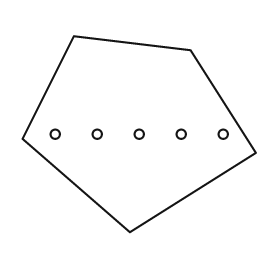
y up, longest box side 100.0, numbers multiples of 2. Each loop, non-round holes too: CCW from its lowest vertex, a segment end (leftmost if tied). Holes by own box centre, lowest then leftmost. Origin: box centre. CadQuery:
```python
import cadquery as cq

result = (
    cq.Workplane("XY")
    .moveTo(-4.0, -42.0)
    .lineTo(50.0, -8.0)
    .lineTo(22.0, 36.0)
    .lineTo(-28.0, 42.0)
    .lineTo(-50.0, -2.0)
    .close()
    .moveTo(-36.0, 0.0)
    .circle(2.0)
    .moveTo(-18.0, 0.0)
    .circle(2.0)
    .moveTo(0.0, 0.0)
    .circle(2.0)
    .moveTo(18.0, 0.0)
    .circle(2.0)
    .moveTo(36.0, 0.0)
    .circle(2.0)
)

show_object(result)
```